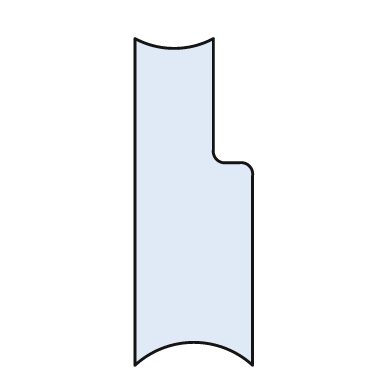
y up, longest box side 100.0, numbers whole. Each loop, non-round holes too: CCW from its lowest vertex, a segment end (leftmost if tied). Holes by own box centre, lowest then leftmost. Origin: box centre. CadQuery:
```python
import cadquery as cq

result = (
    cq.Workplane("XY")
    .moveTo(-18.0, -50.0)
    .threePointArc((0.0, -43.0), (18.0, -50.0))
    .lineTo(18.0, 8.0)
    .threePointArc((17.0, 11.0), (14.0, 12.0))
    .lineTo(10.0, 12.0)
    .threePointArc((7.0, 13.0), (6.0, 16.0))
    .lineTo(6.0, 50.0)
    .threePointArc((-6.0, 47.0), (-18.0, 50.0))
    .close()
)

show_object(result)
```